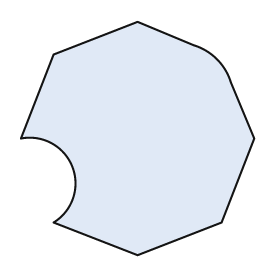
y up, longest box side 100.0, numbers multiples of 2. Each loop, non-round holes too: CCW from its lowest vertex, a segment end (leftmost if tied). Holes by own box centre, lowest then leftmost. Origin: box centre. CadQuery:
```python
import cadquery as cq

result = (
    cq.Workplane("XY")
    .moveTo(0.0, -50.0)
    .lineTo(36.0, -36.0)
    .lineTo(50.0, 0.0)
    .lineTo(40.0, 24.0)
    .threePointArc((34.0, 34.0), (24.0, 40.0))
    .lineTo(0.0, 50.0)
    .lineTo(-36.0, 36.0)
    .lineTo(-50.0, 0.0)
    .threePointArc((-28.0, -12.0), (-36.0, -36.0))
    .close()
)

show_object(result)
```